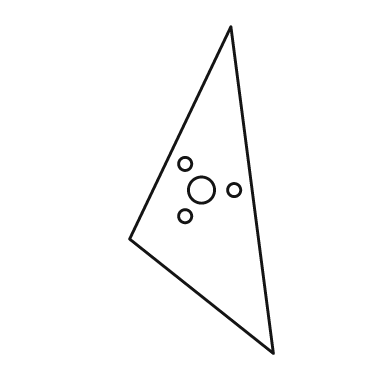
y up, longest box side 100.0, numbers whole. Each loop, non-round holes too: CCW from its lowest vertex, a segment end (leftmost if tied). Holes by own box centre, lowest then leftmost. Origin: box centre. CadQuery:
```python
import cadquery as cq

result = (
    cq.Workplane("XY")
    .moveTo(22.0, -50.0)
    .lineTo(9.0, 50.0)
    .lineTo(-22.0, -15.0)
    .close()
    .moveTo(-5.0, -8.0)
    .circle(2.0)
    .moveTo(0.0, 0.0)
    .circle(4.0)
    .moveTo(10.0, 0.0)
    .circle(2.0)
    .moveTo(-5.0, 8.0)
    .circle(2.0)
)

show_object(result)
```